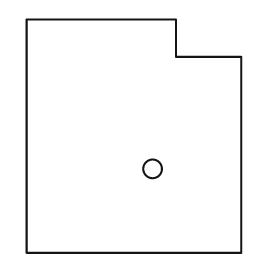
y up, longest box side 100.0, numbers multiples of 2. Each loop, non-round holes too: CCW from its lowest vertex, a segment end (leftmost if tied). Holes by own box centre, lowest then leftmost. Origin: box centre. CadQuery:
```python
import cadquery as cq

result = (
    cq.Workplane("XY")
    .moveTo(-46.0, -50.0)
    .lineTo(46.0, -50.0)
    .lineTo(46.0, 34.0)
    .lineTo(18.0, 34.0)
    .lineTo(18.0, 50.0)
    .lineTo(-46.0, 50.0)
    .close()
    .moveTo(8.0, -14.0)
    .circle(4.0)
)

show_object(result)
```